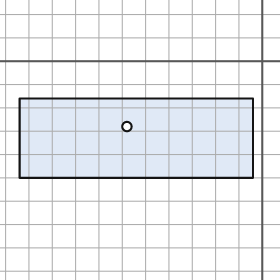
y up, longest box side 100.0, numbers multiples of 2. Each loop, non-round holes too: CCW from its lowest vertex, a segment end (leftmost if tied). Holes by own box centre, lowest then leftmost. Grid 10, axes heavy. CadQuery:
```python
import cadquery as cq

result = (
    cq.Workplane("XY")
    .moveTo(-104.0, -50.0)
    .lineTo(-4.0, -50.0)
    .lineTo(-4.0, -16.0)
    .lineTo(-104.0, -16.0)
    .close()
    .moveTo(-58.0, -28.0)
    .circle(2.0)
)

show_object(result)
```